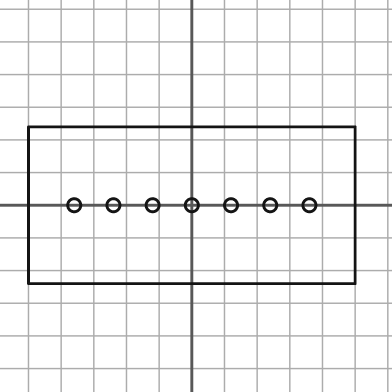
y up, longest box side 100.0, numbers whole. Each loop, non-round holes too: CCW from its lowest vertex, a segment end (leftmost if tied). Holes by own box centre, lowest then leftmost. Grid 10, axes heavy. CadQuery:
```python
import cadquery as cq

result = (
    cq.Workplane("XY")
    .moveTo(-50.0, -24.0)
    .lineTo(50.0, -24.0)
    .lineTo(50.0, 24.0)
    .lineTo(-50.0, 24.0)
    .close()
    .moveTo(-36.0, 0.0)
    .circle(2.0)
    .moveTo(-24.0, 0.0)
    .circle(2.0)
    .moveTo(-12.0, 0.0)
    .circle(2.0)
    .moveTo(0.0, 0.0)
    .circle(2.0)
    .moveTo(12.0, 0.0)
    .circle(2.0)
    .moveTo(24.0, 0.0)
    .circle(2.0)
    .moveTo(36.0, 0.0)
    .circle(2.0)
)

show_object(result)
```